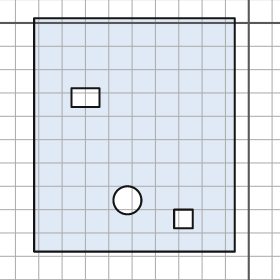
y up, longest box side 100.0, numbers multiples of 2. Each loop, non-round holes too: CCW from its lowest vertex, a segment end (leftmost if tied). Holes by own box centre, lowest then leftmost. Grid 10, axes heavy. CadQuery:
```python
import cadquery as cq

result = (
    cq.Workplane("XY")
    .moveTo(-92.0, -98.0)
    .lineTo(-6.0, -98.0)
    .lineTo(-6.0, 2.0)
    .lineTo(-92.0, 2.0)
    .close()
    .moveTo(-32.0, -88.0)
    .lineTo(-24.0, -88.0)
    .lineTo(-24.0, -80.0)
    .lineTo(-32.0, -80.0)
    .close()
    .moveTo(-52.0, -76.0)
    .circle(6.0)
    .moveTo(-76.0, -36.0)
    .lineTo(-64.0, -36.0)
    .lineTo(-64.0, -28.0)
    .lineTo(-76.0, -28.0)
    .close()
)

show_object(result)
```